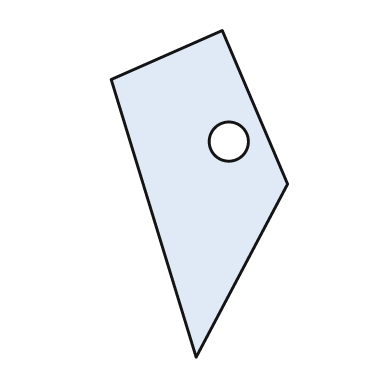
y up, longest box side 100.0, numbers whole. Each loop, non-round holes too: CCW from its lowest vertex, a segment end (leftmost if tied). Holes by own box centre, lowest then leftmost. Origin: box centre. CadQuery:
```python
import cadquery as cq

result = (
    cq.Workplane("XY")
    .moveTo(-1.0, -50.0)
    .lineTo(27.0, 3.0)
    .lineTo(7.0, 50.0)
    .lineTo(-27.0, 35.0)
    .close()
    .moveTo(9.0, 16.0)
    .circle(6.0)
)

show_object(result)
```